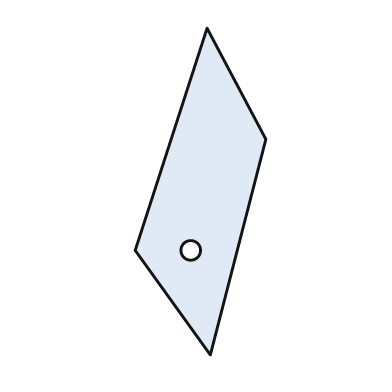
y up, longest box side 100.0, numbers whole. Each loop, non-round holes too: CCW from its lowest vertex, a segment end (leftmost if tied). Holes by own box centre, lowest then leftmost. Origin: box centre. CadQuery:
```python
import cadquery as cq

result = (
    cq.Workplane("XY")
    .moveTo(3.0, -50.0)
    .lineTo(20.0, 16.0)
    .lineTo(2.0, 50.0)
    .lineTo(-20.0, -18.0)
    .close()
    .moveTo(-3.0, -18.0)
    .circle(3.0)
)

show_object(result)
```